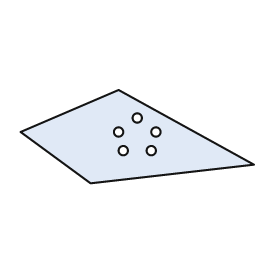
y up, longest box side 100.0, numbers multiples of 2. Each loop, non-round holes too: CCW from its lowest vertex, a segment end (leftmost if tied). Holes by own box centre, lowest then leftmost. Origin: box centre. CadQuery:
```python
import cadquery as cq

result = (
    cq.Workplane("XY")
    .moveTo(-20.0, -20.0)
    .lineTo(50.0, -12.0)
    .lineTo(-8.0, 20.0)
    .lineTo(-50.0, 2.0)
    .close()
    .moveTo(-6.0, -6.0)
    .circle(2.0)
    .moveTo(6.0, -6.0)
    .circle(2.0)
    .moveTo(-8.0, 2.0)
    .circle(2.0)
    .moveTo(8.0, 2.0)
    .circle(2.0)
    .moveTo(0.0, 8.0)
    .circle(2.0)
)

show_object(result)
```